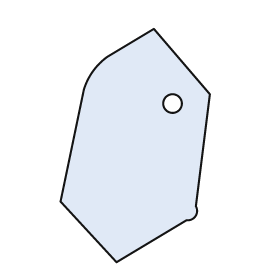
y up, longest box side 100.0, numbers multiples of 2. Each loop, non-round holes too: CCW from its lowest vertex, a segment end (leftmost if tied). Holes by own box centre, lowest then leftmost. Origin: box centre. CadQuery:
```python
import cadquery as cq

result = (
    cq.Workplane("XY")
    .moveTo(-8.0, -50.0)
    .lineTo(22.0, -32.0)
    .threePointArc((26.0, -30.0), (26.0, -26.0))
    .lineTo(32.0, 22.0)
    .lineTo(8.0, 50.0)
    .lineTo(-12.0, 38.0)
    .threePointArc((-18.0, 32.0), (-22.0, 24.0))
    .lineTo(-32.0, -24.0)
    .close()
    .moveTo(16.0, 18.0)
    .circle(4.0)
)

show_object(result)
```